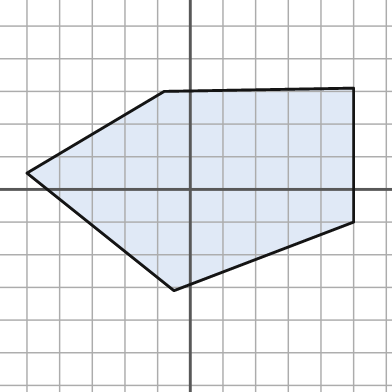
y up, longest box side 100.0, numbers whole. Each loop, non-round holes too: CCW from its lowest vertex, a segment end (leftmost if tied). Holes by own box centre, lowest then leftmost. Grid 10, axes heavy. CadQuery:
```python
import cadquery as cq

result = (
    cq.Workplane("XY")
    .moveTo(-5.0, -31.0)
    .lineTo(50.0, -10.0)
    .lineTo(50.0, 31.0)
    .lineTo(-8.0, 30.0)
    .lineTo(-50.0, 5.0)
    .close()
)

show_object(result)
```